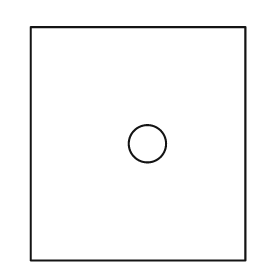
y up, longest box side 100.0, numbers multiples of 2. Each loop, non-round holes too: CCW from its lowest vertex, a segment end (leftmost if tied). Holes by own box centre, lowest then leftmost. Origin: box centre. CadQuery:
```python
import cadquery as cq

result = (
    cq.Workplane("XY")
    .moveTo(-46.0, -50.0)
    .lineTo(46.0, -50.0)
    .lineTo(46.0, 50.0)
    .lineTo(-46.0, 50.0)
    .close()
    .moveTo(4.0, 0.0)
    .circle(8.0)
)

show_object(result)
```